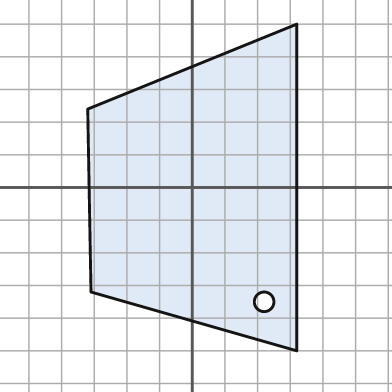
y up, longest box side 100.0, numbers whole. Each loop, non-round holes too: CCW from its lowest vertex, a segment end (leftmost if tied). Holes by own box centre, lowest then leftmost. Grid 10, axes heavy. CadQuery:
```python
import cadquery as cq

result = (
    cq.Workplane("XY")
    .moveTo(32.0, -50.0)
    .lineTo(32.0, 50.0)
    .lineTo(-32.0, 24.0)
    .lineTo(-31.0, -32.0)
    .close()
    .moveTo(22.0, -35.0)
    .circle(3.0)
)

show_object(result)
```